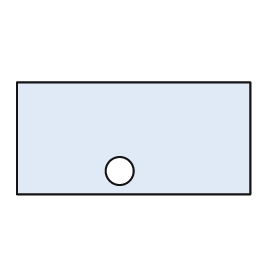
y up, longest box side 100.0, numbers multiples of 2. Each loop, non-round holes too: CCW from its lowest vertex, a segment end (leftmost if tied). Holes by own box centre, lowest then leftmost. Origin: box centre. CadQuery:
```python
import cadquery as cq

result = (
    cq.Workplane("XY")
    .moveTo(-50.0, -24.0)
    .lineTo(50.0, -24.0)
    .lineTo(50.0, 24.0)
    .lineTo(-50.0, 24.0)
    .close()
    .moveTo(-6.0, -14.0)
    .circle(6.0)
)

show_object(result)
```